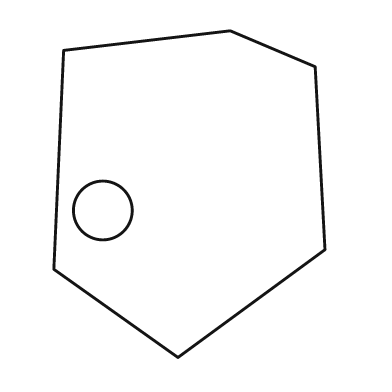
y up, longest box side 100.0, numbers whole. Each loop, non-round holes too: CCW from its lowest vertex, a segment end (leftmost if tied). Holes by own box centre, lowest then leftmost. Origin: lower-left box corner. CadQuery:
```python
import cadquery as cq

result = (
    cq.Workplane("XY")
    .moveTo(38.0, 0.0)
    .lineTo(83.0, 33.0)
    .lineTo(80.0, 89.0)
    .lineTo(54.0, 100.0)
    .lineTo(3.0, 94.0)
    .lineTo(0.0, 27.0)
    .close()
    .moveTo(15.0, 45.0)
    .circle(9.0)
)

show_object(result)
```